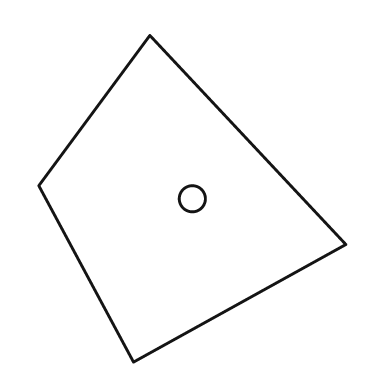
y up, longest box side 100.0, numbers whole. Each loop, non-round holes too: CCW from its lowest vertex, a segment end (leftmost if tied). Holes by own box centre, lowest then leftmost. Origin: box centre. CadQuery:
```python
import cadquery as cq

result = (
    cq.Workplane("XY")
    .moveTo(-18.0, -50.0)
    .lineTo(47.0, -14.0)
    .lineTo(-13.0, 50.0)
    .lineTo(-47.0, 4.0)
    .close()
    .moveTo(0.0, 0.0)
    .circle(4.0)
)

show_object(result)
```